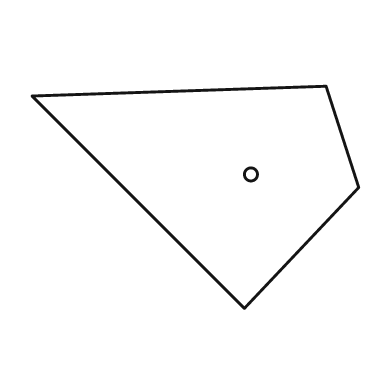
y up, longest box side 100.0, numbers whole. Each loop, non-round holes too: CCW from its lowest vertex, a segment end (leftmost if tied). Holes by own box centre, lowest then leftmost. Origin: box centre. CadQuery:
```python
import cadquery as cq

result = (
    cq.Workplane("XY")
    .moveTo(15.0, -34.0)
    .lineTo(50.0, 3.0)
    .lineTo(40.0, 34.0)
    .lineTo(-50.0, 31.0)
    .close()
    .moveTo(17.0, 7.0)
    .circle(2.0)
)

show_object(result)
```